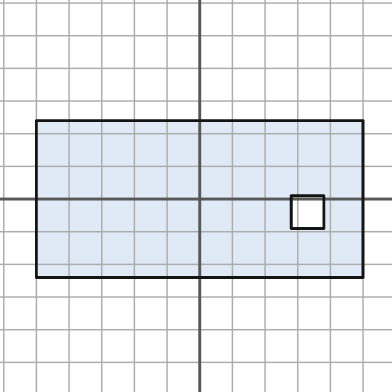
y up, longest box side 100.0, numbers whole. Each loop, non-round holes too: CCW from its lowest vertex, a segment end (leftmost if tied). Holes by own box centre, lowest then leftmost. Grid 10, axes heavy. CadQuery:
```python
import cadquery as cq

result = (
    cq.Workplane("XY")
    .moveTo(-50.0, -24.0)
    .lineTo(50.0, -24.0)
    .lineTo(50.0, 24.0)
    .lineTo(-50.0, 24.0)
    .close()
    .moveTo(28.0, -9.0)
    .lineTo(38.0, -9.0)
    .lineTo(38.0, 1.0)
    .lineTo(28.0, 1.0)
    .close()
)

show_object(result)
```